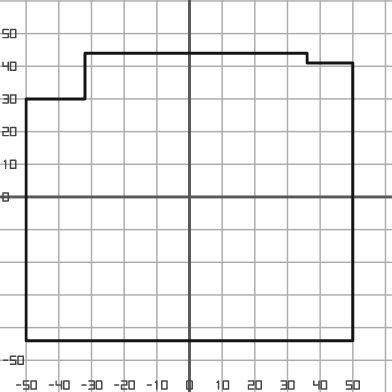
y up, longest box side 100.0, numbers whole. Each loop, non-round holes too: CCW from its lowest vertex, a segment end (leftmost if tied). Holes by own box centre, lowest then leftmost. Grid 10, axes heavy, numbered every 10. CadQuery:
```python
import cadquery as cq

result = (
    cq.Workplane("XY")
    .moveTo(-50.0, -44.0)
    .lineTo(50.0, -44.0)
    .lineTo(50.0, 41.0)
    .lineTo(36.0, 41.0)
    .lineTo(36.0, 44.0)
    .lineTo(-32.0, 44.0)
    .lineTo(-32.0, 30.0)
    .lineTo(-50.0, 30.0)
    .close()
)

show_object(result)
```